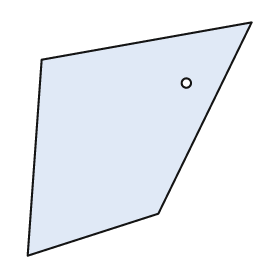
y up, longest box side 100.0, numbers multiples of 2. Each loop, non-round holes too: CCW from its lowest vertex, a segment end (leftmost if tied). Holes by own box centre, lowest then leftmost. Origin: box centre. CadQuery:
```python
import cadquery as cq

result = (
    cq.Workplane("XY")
    .moveTo(-48.0, -50.0)
    .lineTo(8.0, -32.0)
    .lineTo(48.0, 50.0)
    .lineTo(-42.0, 34.0)
    .close()
    .moveTo(20.0, 24.0)
    .circle(2.0)
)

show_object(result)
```